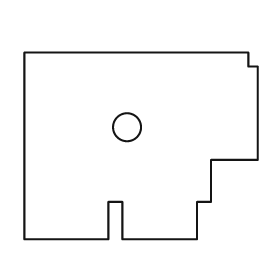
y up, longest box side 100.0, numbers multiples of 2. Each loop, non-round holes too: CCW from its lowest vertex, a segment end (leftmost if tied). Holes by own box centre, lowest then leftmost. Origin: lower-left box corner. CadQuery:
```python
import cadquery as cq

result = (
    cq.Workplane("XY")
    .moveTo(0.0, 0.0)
    .lineTo(36.0, 0.0)
    .lineTo(36.0, 16.0)
    .lineTo(42.0, 16.0)
    .lineTo(42.0, 0.0)
    .lineTo(74.0, 0.0)
    .lineTo(74.0, 16.0)
    .lineTo(80.0, 16.0)
    .lineTo(80.0, 34.0)
    .lineTo(100.0, 34.0)
    .lineTo(100.0, 74.0)
    .lineTo(96.0, 74.0)
    .lineTo(96.0, 80.0)
    .lineTo(0.0, 80.0)
    .close()
    .moveTo(44.0, 48.0)
    .circle(6.0)
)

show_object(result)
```